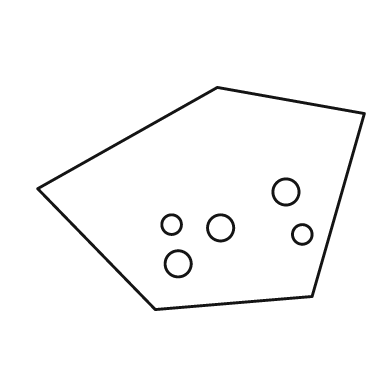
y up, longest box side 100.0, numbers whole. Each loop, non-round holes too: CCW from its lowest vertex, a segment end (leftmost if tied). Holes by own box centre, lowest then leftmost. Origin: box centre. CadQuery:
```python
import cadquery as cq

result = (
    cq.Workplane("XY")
    .moveTo(-14.0, -34.0)
    .lineTo(34.0, -30.0)
    .lineTo(50.0, 26.0)
    .lineTo(5.0, 34.0)
    .lineTo(-50.0, 3.0)
    .close()
    .moveTo(-7.0, -20.0)
    .circle(4.0)
    .moveTo(31.0, -11.0)
    .circle(3.0)
    .moveTo(6.0, -9.0)
    .circle(4.0)
    .moveTo(-9.0, -8.0)
    .circle(3.0)
    .moveTo(26.0, 2.0)
    .circle(4.0)
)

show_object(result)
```